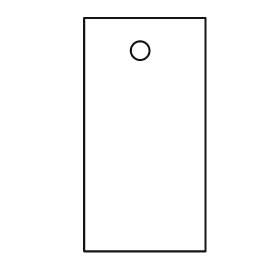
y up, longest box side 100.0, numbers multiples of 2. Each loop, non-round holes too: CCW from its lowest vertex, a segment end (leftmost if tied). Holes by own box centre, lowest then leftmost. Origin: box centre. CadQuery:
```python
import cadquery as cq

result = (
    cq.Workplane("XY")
    .moveTo(-26.0, -50.0)
    .lineTo(26.0, -50.0)
    .lineTo(26.0, 50.0)
    .lineTo(-26.0, 50.0)
    .close()
    .moveTo(-2.0, 36.0)
    .circle(4.0)
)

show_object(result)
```